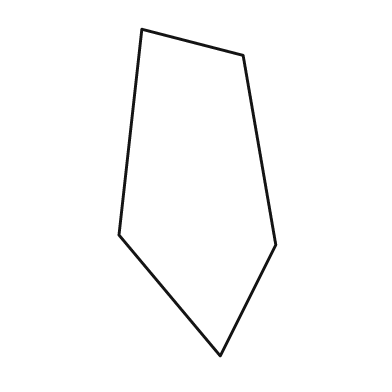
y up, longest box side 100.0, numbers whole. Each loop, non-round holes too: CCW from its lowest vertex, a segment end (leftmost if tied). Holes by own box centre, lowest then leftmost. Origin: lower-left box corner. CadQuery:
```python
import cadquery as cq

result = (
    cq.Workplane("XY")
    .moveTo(31.0, 0.0)
    .lineTo(48.0, 34.0)
    .lineTo(38.0, 92.0)
    .lineTo(7.0, 100.0)
    .lineTo(0.0, 37.0)
    .close()
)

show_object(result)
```